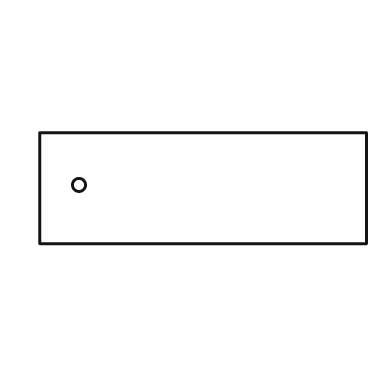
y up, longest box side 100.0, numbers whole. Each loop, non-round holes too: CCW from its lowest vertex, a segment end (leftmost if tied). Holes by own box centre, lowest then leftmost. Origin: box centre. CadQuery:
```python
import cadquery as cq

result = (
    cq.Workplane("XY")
    .moveTo(-50.0, -17.0)
    .lineTo(50.0, -17.0)
    .lineTo(50.0, 17.0)
    .lineTo(-50.0, 17.0)
    .close()
    .moveTo(-38.0, 1.0)
    .circle(2.0)
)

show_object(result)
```